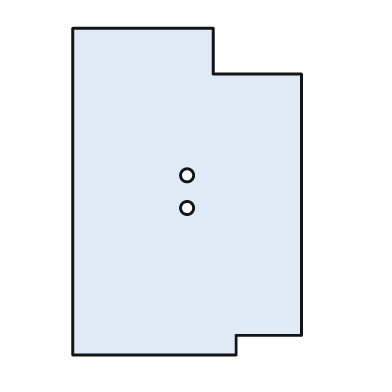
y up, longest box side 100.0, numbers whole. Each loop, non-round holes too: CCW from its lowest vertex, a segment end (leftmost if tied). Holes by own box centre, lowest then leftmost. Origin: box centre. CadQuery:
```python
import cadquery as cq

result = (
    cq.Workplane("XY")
    .moveTo(-35.0, -50.0)
    .lineTo(15.0, -50.0)
    .lineTo(15.0, -44.0)
    .lineTo(35.0, -44.0)
    .lineTo(35.0, 36.0)
    .lineTo(8.0, 36.0)
    .lineTo(8.0, 50.0)
    .lineTo(-35.0, 50.0)
    .close()
    .moveTo(0.0, -5.0)
    .circle(2.0)
    .moveTo(0.0, 5.0)
    .circle(2.0)
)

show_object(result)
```